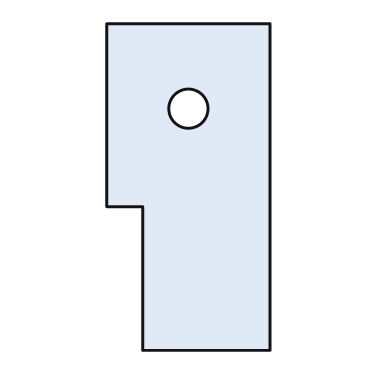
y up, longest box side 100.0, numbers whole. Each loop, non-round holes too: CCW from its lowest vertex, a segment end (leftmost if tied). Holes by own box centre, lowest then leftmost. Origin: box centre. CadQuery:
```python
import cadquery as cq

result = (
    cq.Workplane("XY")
    .moveTo(-14.0, -50.0)
    .lineTo(25.0, -50.0)
    .lineTo(25.0, 50.0)
    .lineTo(-25.0, 50.0)
    .lineTo(-25.0, -6.0)
    .lineTo(-14.0, -6.0)
    .close()
    .moveTo(0.0, 24.0)
    .circle(6.0)
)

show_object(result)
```